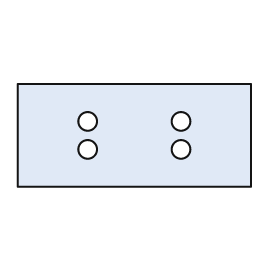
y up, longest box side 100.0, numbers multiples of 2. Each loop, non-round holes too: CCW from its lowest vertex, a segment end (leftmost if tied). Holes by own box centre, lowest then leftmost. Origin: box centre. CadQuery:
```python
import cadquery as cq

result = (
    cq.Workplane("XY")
    .moveTo(-50.0, -22.0)
    .lineTo(50.0, -22.0)
    .lineTo(50.0, 22.0)
    .lineTo(-50.0, 22.0)
    .close()
    .moveTo(-20.0, -6.0)
    .circle(4.0)
    .moveTo(20.0, -6.0)
    .circle(4.0)
    .moveTo(-20.0, 6.0)
    .circle(4.0)
    .moveTo(20.0, 6.0)
    .circle(4.0)
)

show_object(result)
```